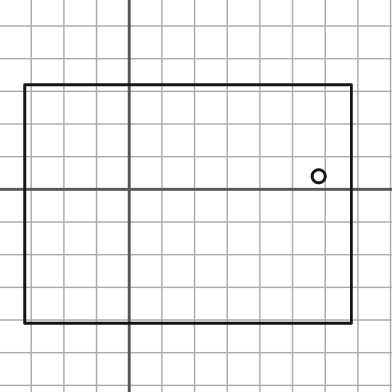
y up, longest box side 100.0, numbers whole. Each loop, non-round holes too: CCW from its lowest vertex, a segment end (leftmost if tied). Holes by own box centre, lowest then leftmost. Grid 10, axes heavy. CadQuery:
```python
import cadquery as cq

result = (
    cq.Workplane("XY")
    .moveTo(-32.0, -41.0)
    .lineTo(68.0, -41.0)
    .lineTo(68.0, 32.0)
    .lineTo(-32.0, 32.0)
    .close()
    .moveTo(58.0, 4.0)
    .circle(2.0)
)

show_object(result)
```